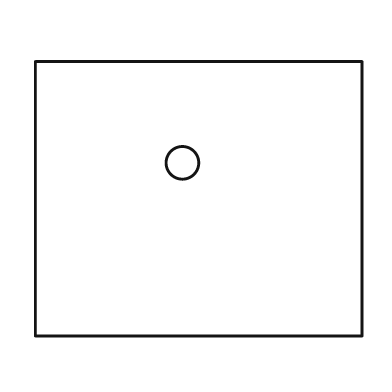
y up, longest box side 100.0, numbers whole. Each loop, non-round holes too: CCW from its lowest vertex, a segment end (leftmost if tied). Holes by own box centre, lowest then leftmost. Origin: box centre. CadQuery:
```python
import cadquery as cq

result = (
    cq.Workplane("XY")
    .moveTo(-50.0, -42.0)
    .lineTo(50.0, -42.0)
    .lineTo(50.0, 42.0)
    .lineTo(-50.0, 42.0)
    .close()
    .moveTo(-5.0, 11.0)
    .circle(5.0)
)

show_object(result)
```